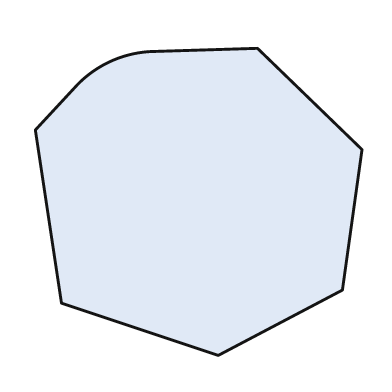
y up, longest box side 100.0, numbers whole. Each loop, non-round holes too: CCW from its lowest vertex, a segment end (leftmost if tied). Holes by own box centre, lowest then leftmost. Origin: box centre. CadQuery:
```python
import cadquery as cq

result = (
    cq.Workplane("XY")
    .moveTo(6.0, -47.0)
    .lineTo(44.0, -27.0)
    .lineTo(50.0, 16.0)
    .lineTo(18.0, 47.0)
    .lineTo(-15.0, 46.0)
    .threePointArc((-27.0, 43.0), (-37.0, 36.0))
    .lineTo(-50.0, 22.0)
    .lineTo(-42.0, -31.0)
    .close()
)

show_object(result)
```